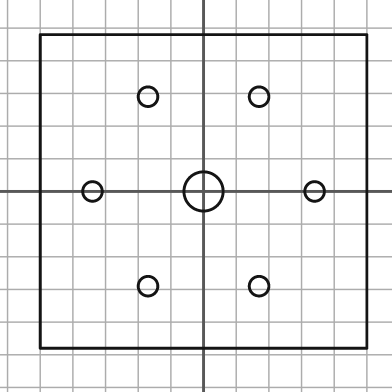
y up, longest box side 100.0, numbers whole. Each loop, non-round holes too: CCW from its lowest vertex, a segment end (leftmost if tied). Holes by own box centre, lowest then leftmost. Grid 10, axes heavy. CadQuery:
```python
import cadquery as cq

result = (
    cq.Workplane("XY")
    .moveTo(-50.0, -48.0)
    .lineTo(50.0, -48.0)
    .lineTo(50.0, 48.0)
    .lineTo(-50.0, 48.0)
    .close()
    .moveTo(-17.0, -29.0)
    .circle(3.0)
    .moveTo(17.0, -29.0)
    .circle(3.0)
    .moveTo(-34.0, 0.0)
    .circle(3.0)
    .moveTo(0.0, 0.0)
    .circle(6.0)
    .moveTo(34.0, 0.0)
    .circle(3.0)
    .moveTo(-17.0, 29.0)
    .circle(3.0)
    .moveTo(17.0, 29.0)
    .circle(3.0)
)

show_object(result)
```